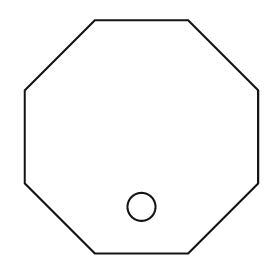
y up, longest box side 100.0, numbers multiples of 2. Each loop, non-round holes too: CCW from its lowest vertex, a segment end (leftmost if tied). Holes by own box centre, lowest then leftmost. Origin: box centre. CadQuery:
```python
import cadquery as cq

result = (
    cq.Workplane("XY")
    .moveTo(-20.0, -50.0)
    .lineTo(20.0, -50.0)
    .lineTo(50.0, -20.0)
    .lineTo(50.0, 20.0)
    .lineTo(20.0, 50.0)
    .lineTo(-20.0, 50.0)
    .lineTo(-50.0, 20.0)
    .lineTo(-50.0, -20.0)
    .close()
    .moveTo(0.0, -30.0)
    .circle(6.0)
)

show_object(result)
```